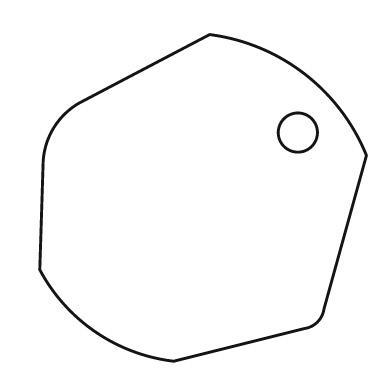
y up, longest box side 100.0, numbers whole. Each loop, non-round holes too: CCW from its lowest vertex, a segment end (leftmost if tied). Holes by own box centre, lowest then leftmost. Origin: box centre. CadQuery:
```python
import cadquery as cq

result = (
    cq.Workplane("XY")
    .moveTo(-9.0, -50.0)
    .lineTo(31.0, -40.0)
    .threePointArc((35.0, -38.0), (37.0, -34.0))
    .lineTo(50.0, 13.0)
    .threePointArc((31.0, 38.0), (2.0, 50.0))
    .lineTo(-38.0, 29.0)
    .threePointArc((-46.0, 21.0), (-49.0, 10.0))
    .lineTo(-50.0, -22.0)
    .threePointArc((-33.0, -41.0), (-9.0, -50.0))
    .close()
    .moveTo(29.0, 20.0)
    .circle(6.0)
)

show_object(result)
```